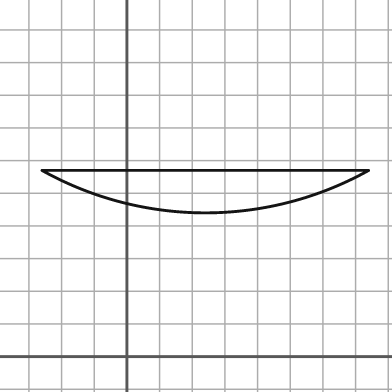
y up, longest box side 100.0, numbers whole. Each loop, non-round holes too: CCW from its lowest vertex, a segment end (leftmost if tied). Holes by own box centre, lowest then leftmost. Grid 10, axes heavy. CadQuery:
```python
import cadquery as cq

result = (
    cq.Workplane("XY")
    .moveTo(-26.0, 57.0)
    .threePointArc((24.0, 44.0), (74.0, 57.0))
    .close()
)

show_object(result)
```